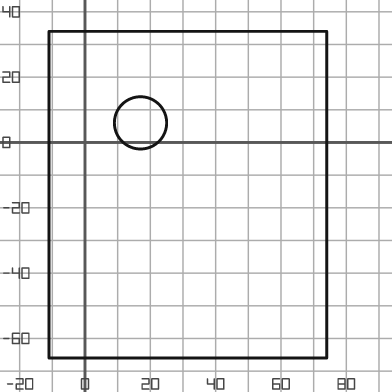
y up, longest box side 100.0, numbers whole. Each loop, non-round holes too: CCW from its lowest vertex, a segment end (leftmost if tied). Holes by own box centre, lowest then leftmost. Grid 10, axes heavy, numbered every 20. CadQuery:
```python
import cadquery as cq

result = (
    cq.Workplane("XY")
    .moveTo(-11.0, -66.0)
    .lineTo(74.0, -66.0)
    .lineTo(74.0, 34.0)
    .lineTo(-11.0, 34.0)
    .close()
    .moveTo(17.0, 6.0)
    .circle(8.0)
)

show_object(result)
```